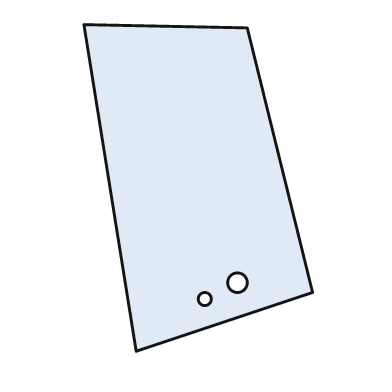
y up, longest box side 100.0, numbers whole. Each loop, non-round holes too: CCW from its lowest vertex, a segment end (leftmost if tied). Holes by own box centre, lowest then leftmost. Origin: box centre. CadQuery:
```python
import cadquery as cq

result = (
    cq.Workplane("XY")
    .moveTo(-19.0, -50.0)
    .lineTo(35.0, -32.0)
    .lineTo(15.0, 49.0)
    .lineTo(-35.0, 50.0)
    .close()
    .moveTo(2.0, -34.0)
    .circle(2.0)
    .moveTo(12.0, -29.0)
    .circle(3.0)
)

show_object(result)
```